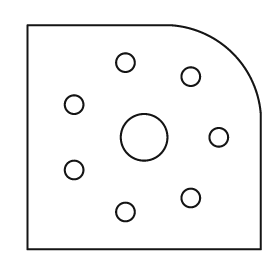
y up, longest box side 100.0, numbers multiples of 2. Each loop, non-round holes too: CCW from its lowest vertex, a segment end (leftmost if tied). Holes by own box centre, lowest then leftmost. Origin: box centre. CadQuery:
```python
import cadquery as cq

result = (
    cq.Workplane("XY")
    .moveTo(-50.0, -48.0)
    .lineTo(50.0, -48.0)
    .lineTo(50.0, 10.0)
    .threePointArc((38.0, 36.0), (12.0, 48.0))
    .lineTo(-50.0, 48.0)
    .close()
    .moveTo(-8.0, -32.0)
    .circle(4.0)
    .moveTo(20.0, -26.0)
    .circle(4.0)
    .moveTo(-30.0, -14.0)
    .circle(4.0)
    .moveTo(0.0, 0.0)
    .circle(10.0)
    .moveTo(32.0, 0.0)
    .circle(4.0)
    .moveTo(-30.0, 14.0)
    .circle(4.0)
    .moveTo(20.0, 26.0)
    .circle(4.0)
    .moveTo(-8.0, 32.0)
    .circle(4.0)
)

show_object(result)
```